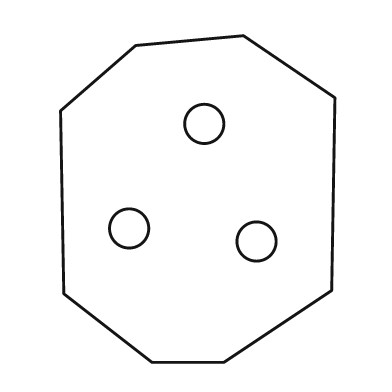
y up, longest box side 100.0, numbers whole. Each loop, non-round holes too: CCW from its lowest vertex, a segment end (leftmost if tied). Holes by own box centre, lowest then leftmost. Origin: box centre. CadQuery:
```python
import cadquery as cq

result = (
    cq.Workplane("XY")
    .moveTo(-14.0, -50.0)
    .lineTo(8.0, -50.0)
    .lineTo(41.0, -28.0)
    .lineTo(42.0, 31.0)
    .lineTo(14.0, 50.0)
    .lineTo(-19.0, 47.0)
    .lineTo(-42.0, 27.0)
    .lineTo(-41.0, -29.0)
    .close()
    .moveTo(18.0, -13.0)
    .circle(6.0)
    .moveTo(-21.0, -9.0)
    .circle(6.0)
    .moveTo(2.0, 23.0)
    .circle(6.0)
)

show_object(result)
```